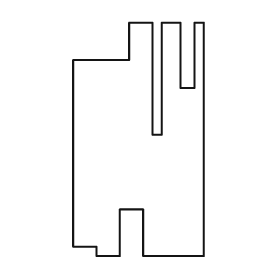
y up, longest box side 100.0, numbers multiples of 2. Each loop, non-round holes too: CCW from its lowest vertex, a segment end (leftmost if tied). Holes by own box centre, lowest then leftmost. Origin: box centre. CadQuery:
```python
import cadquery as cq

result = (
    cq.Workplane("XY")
    .moveTo(-18.0, -50.0)
    .lineTo(-8.0, -50.0)
    .lineTo(-8.0, -30.0)
    .lineTo(2.0, -30.0)
    .lineTo(2.0, -50.0)
    .lineTo(28.0, -50.0)
    .lineTo(28.0, 50.0)
    .lineTo(24.0, 50.0)
    .lineTo(24.0, 22.0)
    .lineTo(18.0, 22.0)
    .lineTo(18.0, 50.0)
    .lineTo(10.0, 50.0)
    .lineTo(10.0, 2.0)
    .lineTo(6.0, 2.0)
    .lineTo(6.0, 50.0)
    .lineTo(-4.0, 50.0)
    .lineTo(-4.0, 34.0)
    .lineTo(-28.0, 34.0)
    .lineTo(-28.0, -46.0)
    .lineTo(-18.0, -46.0)
    .close()
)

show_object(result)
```